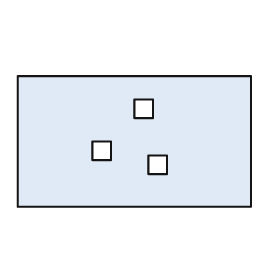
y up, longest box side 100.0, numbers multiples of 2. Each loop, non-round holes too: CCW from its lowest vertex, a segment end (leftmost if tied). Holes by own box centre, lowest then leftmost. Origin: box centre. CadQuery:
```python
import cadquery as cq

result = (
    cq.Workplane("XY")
    .moveTo(-50.0, -28.0)
    .lineTo(50.0, -28.0)
    .lineTo(50.0, 28.0)
    .lineTo(-50.0, 28.0)
    .close()
    .moveTo(6.0, -14.0)
    .lineTo(14.0, -14.0)
    .lineTo(14.0, -6.0)
    .lineTo(6.0, -6.0)
    .close()
    .moveTo(-18.0, -8.0)
    .lineTo(-10.0, -8.0)
    .lineTo(-10.0, 0.0)
    .lineTo(-18.0, 0.0)
    .close()
    .moveTo(0.0, 10.0)
    .lineTo(8.0, 10.0)
    .lineTo(8.0, 18.0)
    .lineTo(0.0, 18.0)
    .close()
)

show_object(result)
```